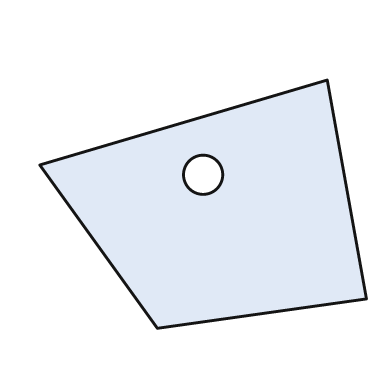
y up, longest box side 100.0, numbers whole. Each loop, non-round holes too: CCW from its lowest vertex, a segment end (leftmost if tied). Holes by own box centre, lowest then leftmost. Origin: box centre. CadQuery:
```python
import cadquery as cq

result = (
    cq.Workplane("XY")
    .moveTo(-14.0, -38.0)
    .lineTo(50.0, -29.0)
    .lineTo(38.0, 38.0)
    .lineTo(-50.0, 12.0)
    .close()
    .moveTo(0.0, 9.0)
    .circle(6.0)
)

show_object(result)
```